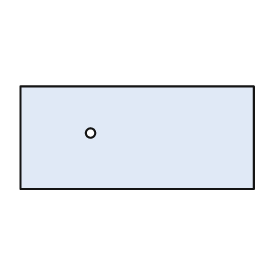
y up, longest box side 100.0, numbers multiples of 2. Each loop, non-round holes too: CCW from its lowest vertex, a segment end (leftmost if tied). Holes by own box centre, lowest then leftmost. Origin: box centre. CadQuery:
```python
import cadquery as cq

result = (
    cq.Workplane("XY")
    .moveTo(-50.0, -22.0)
    .lineTo(50.0, -22.0)
    .lineTo(50.0, 22.0)
    .lineTo(-50.0, 22.0)
    .close()
    .moveTo(-20.0, 2.0)
    .circle(2.0)
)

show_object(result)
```